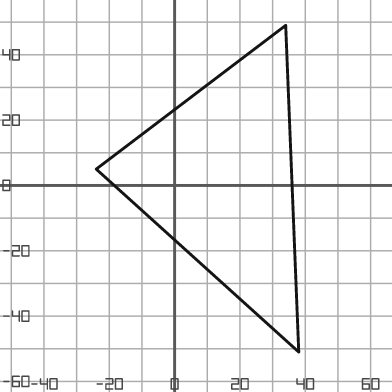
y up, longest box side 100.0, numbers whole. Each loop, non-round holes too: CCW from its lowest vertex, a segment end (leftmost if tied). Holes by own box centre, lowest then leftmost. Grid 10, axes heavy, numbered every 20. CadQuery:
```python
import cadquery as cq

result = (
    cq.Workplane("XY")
    .moveTo(38.0, -51.0)
    .lineTo(34.0, 49.0)
    .lineTo(-24.0, 5.0)
    .close()
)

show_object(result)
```